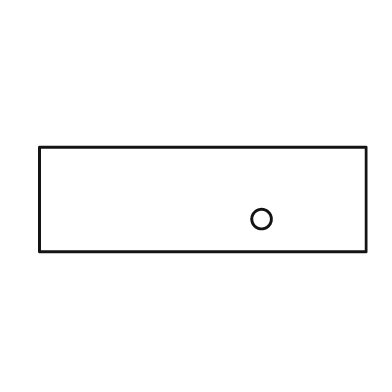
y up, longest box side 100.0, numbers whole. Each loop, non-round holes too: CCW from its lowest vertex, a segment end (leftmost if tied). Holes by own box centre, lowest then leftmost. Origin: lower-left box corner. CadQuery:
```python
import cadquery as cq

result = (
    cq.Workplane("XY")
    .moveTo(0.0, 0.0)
    .lineTo(100.0, 0.0)
    .lineTo(100.0, 32.0)
    .lineTo(0.0, 32.0)
    .close()
    .moveTo(68.0, 10.0)
    .circle(3.0)
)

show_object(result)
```